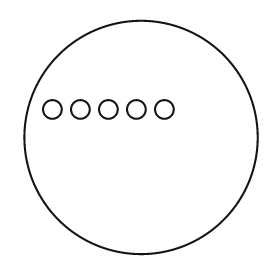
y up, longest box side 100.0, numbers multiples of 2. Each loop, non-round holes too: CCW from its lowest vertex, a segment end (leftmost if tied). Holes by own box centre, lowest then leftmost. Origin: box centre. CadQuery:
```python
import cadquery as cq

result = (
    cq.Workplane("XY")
    .moveTo(0.0, 0.0)
    .circle(50.0)
    .moveTo(-38.0, 12.0)
    .circle(4.0)
    .moveTo(-26.0, 12.0)
    .circle(4.0)
    .moveTo(-14.0, 12.0)
    .circle(4.0)
    .moveTo(-2.0, 12.0)
    .circle(4.0)
    .moveTo(10.0, 12.0)
    .circle(4.0)
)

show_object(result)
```